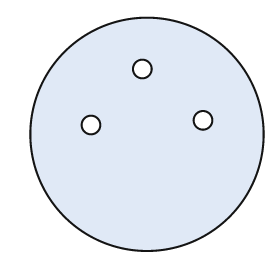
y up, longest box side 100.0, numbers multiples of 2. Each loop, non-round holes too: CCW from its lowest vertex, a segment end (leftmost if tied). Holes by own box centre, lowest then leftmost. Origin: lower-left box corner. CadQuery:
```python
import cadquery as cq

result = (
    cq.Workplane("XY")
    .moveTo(50.0, 50.0)
    .circle(50.0)
    .moveTo(26.0, 54.0)
    .circle(4.0)
    .moveTo(74.0, 56.0)
    .circle(4.0)
    .moveTo(48.0, 78.0)
    .circle(4.0)
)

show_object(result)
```